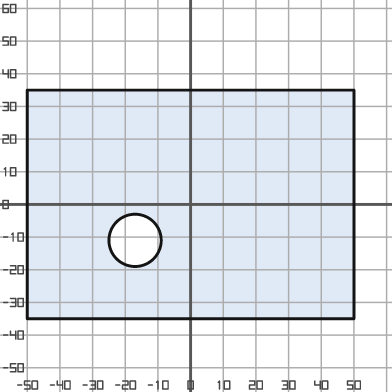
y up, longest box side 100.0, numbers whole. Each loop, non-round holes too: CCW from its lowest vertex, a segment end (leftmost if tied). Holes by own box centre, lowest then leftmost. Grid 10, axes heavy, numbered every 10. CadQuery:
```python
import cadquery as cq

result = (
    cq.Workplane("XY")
    .moveTo(-50.0, -35.0)
    .lineTo(50.0, -35.0)
    .lineTo(50.0, 35.0)
    .lineTo(-50.0, 35.0)
    .close()
    .moveTo(-17.0, -11.0)
    .circle(8.0)
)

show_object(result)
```